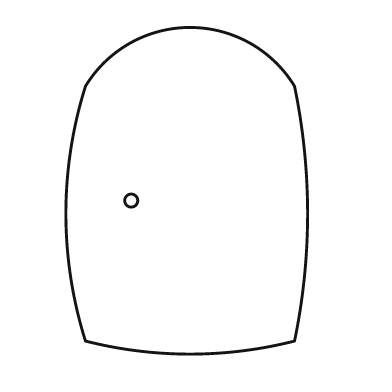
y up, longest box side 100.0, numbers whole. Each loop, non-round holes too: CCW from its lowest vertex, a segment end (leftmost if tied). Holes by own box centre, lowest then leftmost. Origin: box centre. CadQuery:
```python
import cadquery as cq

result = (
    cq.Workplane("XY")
    .moveTo(-31.0, -46.0)
    .threePointArc((1.0, -50.0), (33.0, -46.0))
    .threePointArc((37.0, -7.0), (33.0, 32.0))
    .threePointArc((1.0, 50.0), (-31.0, 32.0))
    .threePointArc((-37.0, -7.0), (-31.0, -46.0))
    .close()
    .moveTo(-17.0, -3.0)
    .circle(2.0)
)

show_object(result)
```